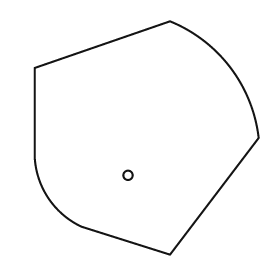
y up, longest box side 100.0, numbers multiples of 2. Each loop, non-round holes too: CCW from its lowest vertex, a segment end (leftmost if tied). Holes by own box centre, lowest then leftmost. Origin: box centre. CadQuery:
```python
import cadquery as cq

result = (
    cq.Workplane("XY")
    .moveTo(10.0, -50.0)
    .lineTo(48.0, 0.0)
    .threePointArc((36.0, 30.0), (10.0, 50.0))
    .lineTo(-48.0, 30.0)
    .lineTo(-48.0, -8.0)
    .threePointArc((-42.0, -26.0), (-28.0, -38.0))
    .close()
    .moveTo(-8.0, -16.0)
    .circle(2.0)
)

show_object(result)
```